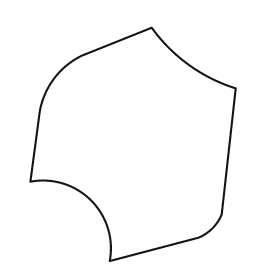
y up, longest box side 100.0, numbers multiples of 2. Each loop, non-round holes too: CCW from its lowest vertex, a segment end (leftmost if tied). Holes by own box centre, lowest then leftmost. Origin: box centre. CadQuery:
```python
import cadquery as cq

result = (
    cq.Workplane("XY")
    .moveTo(-10.0, -50.0)
    .lineTo(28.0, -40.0)
    .threePointArc((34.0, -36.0), (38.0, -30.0))
    .lineTo(44.0, 24.0)
    .threePointArc((24.0, 34.0), (8.0, 50.0))
    .lineTo(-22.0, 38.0)
    .threePointArc((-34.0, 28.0), (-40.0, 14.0))
    .lineTo(-44.0, -16.0)
    .threePointArc((-18.0, -24.0), (-10.0, -50.0))
    .close()
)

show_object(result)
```